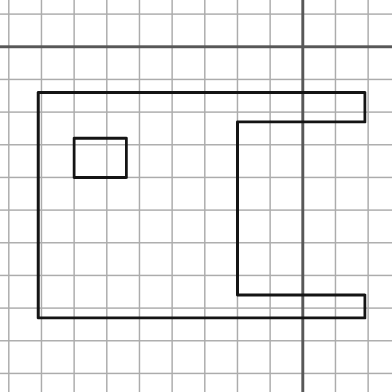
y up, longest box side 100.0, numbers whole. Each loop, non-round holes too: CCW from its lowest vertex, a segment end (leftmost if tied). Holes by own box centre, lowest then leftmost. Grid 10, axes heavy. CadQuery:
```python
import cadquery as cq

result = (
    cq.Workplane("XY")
    .moveTo(-81.0, -83.0)
    .lineTo(19.0, -83.0)
    .lineTo(19.0, -76.0)
    .lineTo(-20.0, -76.0)
    .lineTo(-20.0, -23.0)
    .lineTo(19.0, -23.0)
    .lineTo(19.0, -14.0)
    .lineTo(-81.0, -14.0)
    .close()
    .moveTo(-70.0, -40.0)
    .lineTo(-54.0, -40.0)
    .lineTo(-54.0, -28.0)
    .lineTo(-70.0, -28.0)
    .close()
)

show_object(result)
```